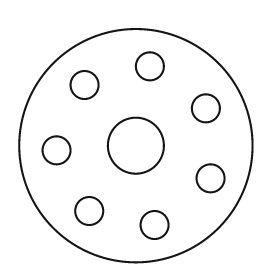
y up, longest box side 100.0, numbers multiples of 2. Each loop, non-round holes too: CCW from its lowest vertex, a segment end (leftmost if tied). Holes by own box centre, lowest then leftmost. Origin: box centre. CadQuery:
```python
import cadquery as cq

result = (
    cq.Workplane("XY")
    .moveTo(0.0, 0.0)
    .circle(50.0)
    .moveTo(8.0, -34.0)
    .circle(6.0)
    .moveTo(-20.0, -28.0)
    .circle(6.0)
    .moveTo(32.0, -14.0)
    .circle(6.0)
    .moveTo(-34.0, -2.0)
    .circle(6.0)
    .moveTo(0.0, 0.0)
    .circle(12.0)
    .moveTo(30.0, 16.0)
    .circle(6.0)
    .moveTo(-22.0, 26.0)
    .circle(6.0)
    .moveTo(6.0, 34.0)
    .circle(6.0)
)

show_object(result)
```